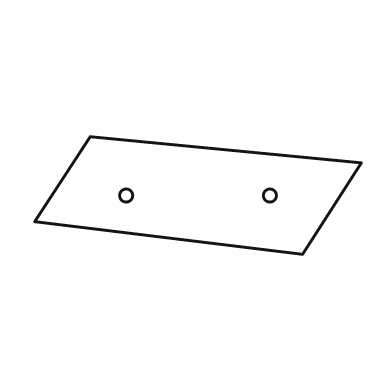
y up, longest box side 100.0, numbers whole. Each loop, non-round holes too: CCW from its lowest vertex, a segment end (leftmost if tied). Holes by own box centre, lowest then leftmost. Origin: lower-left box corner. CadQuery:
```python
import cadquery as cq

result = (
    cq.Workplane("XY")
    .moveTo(82.0, 0.0)
    .lineTo(100.0, 28.0)
    .lineTo(17.0, 36.0)
    .lineTo(0.0, 10.0)
    .close()
    .moveTo(28.0, 18.0)
    .circle(2.0)
    .moveTo(72.0, 18.0)
    .circle(2.0)
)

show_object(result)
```